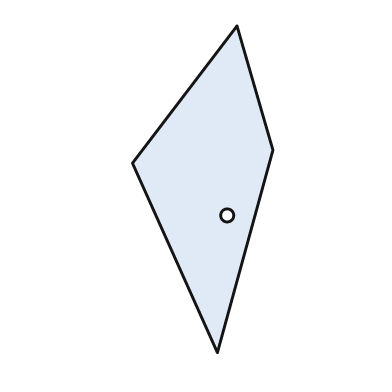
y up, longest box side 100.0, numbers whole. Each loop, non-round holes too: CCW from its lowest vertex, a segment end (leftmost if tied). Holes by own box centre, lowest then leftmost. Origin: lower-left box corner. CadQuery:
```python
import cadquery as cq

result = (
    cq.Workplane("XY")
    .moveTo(26.0, 0.0)
    .lineTo(43.0, 62.0)
    .lineTo(32.0, 100.0)
    .lineTo(0.0, 58.0)
    .close()
    .moveTo(29.0, 42.0)
    .circle(2.0)
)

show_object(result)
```